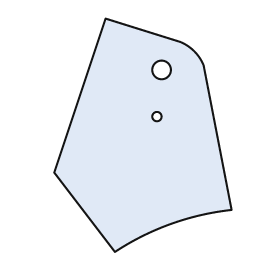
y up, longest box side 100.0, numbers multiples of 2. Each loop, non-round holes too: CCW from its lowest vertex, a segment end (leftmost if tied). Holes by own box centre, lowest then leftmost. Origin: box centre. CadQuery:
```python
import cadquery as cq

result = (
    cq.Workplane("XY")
    .moveTo(-12.0, -50.0)
    .threePointArc((12.0, -38.0), (38.0, -32.0))
    .lineTo(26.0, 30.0)
    .threePointArc((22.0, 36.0), (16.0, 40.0))
    .lineTo(-16.0, 50.0)
    .lineTo(-38.0, -16.0)
    .close()
    .moveTo(6.0, 8.0)
    .circle(2.0)
    .moveTo(8.0, 28.0)
    .circle(4.0)
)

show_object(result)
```